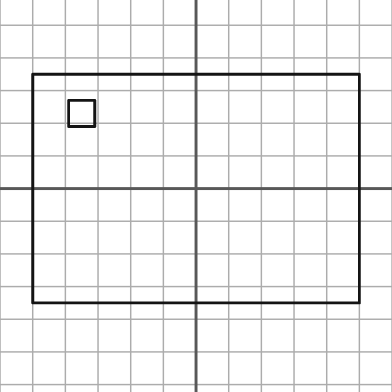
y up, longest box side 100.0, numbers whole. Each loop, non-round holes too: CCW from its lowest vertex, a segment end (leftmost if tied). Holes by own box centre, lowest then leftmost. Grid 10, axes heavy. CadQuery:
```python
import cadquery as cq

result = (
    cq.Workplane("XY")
    .moveTo(-50.0, -35.0)
    .lineTo(50.0, -35.0)
    .lineTo(50.0, 35.0)
    .lineTo(-50.0, 35.0)
    .close()
    .moveTo(-39.0, 19.0)
    .lineTo(-31.0, 19.0)
    .lineTo(-31.0, 27.0)
    .lineTo(-39.0, 27.0)
    .close()
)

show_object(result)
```